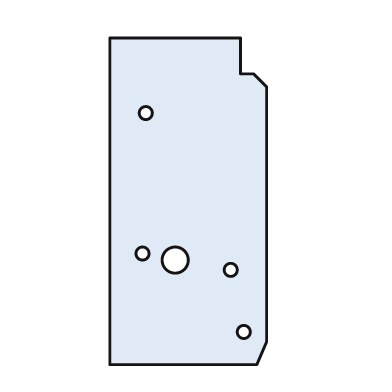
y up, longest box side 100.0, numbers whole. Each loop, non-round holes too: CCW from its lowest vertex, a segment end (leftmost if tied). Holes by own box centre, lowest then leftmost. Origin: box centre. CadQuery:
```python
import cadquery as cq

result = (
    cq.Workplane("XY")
    .moveTo(-24.0, -50.0)
    .lineTo(21.0, -50.0)
    .lineTo(24.0, -43.0)
    .lineTo(24.0, 35.0)
    .lineTo(20.0, 39.0)
    .lineTo(16.0, 39.0)
    .lineTo(16.0, 50.0)
    .lineTo(-24.0, 50.0)
    .close()
    .moveTo(17.0, -40.0)
    .circle(2.0)
    .moveTo(13.0, -21.0)
    .circle(2.0)
    .moveTo(-4.0, -18.0)
    .circle(4.0)
    .moveTo(-14.0, -16.0)
    .circle(2.0)
    .moveTo(-13.0, 27.0)
    .circle(2.0)
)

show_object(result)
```